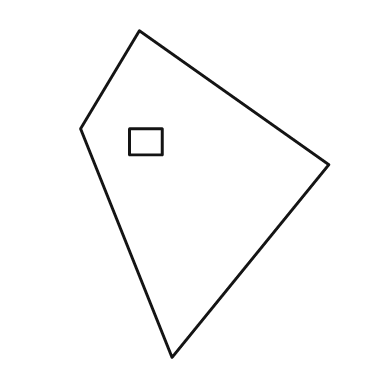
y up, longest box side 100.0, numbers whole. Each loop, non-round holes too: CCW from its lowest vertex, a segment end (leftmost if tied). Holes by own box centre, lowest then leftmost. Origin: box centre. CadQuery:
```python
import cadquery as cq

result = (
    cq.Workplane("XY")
    .moveTo(-10.0, -50.0)
    .lineTo(38.0, 9.0)
    .lineTo(-20.0, 50.0)
    .lineTo(-38.0, 20.0)
    .close()
    .moveTo(-23.0, 12.0)
    .lineTo(-13.0, 12.0)
    .lineTo(-13.0, 20.0)
    .lineTo(-23.0, 20.0)
    .close()
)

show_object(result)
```